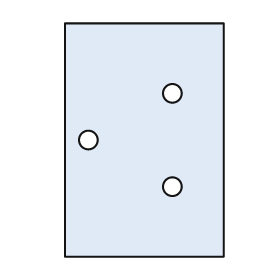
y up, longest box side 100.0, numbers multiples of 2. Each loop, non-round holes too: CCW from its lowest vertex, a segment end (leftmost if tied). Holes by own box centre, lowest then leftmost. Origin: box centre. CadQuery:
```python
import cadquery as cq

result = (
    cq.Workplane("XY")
    .moveTo(-34.0, -50.0)
    .lineTo(34.0, -50.0)
    .lineTo(34.0, 50.0)
    .lineTo(-34.0, 50.0)
    .close()
    .moveTo(12.0, -20.0)
    .circle(4.0)
    .moveTo(-24.0, 0.0)
    .circle(4.0)
    .moveTo(12.0, 20.0)
    .circle(4.0)
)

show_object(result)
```